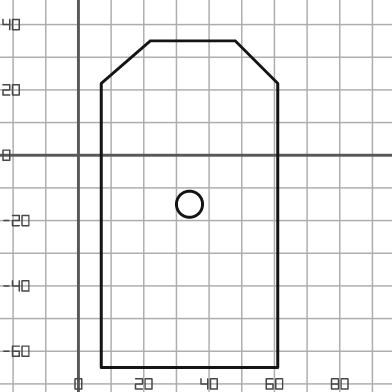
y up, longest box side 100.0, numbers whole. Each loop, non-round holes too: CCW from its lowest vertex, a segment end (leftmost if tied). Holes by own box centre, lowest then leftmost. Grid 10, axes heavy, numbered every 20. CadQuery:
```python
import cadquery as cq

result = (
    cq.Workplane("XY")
    .moveTo(7.0, -65.0)
    .lineTo(61.0, -65.0)
    .lineTo(61.0, 22.0)
    .lineTo(48.0, 35.0)
    .lineTo(22.0, 35.0)
    .lineTo(7.0, 22.0)
    .close()
    .moveTo(34.0, -15.0)
    .circle(4.0)
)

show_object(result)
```